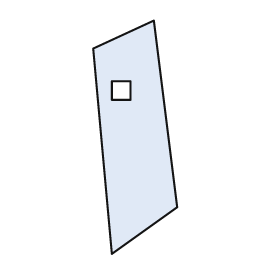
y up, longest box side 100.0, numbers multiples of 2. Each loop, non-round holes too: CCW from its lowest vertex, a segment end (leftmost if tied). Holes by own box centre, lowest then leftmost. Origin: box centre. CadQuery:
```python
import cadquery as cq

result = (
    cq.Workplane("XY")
    .moveTo(-10.0, -50.0)
    .lineTo(18.0, -30.0)
    .lineTo(8.0, 50.0)
    .lineTo(-18.0, 38.0)
    .close()
    .moveTo(-10.0, 16.0)
    .lineTo(-2.0, 16.0)
    .lineTo(-2.0, 24.0)
    .lineTo(-10.0, 24.0)
    .close()
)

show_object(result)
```